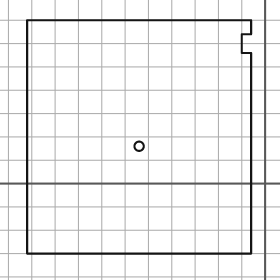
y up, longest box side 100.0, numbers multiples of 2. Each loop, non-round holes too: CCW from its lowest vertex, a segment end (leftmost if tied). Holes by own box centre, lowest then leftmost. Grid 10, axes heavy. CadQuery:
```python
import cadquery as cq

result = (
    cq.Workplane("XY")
    .moveTo(-102.0, -30.0)
    .lineTo(-6.0, -30.0)
    .lineTo(-6.0, 56.0)
    .lineTo(-10.0, 56.0)
    .lineTo(-10.0, 64.0)
    .lineTo(-6.0, 64.0)
    .lineTo(-6.0, 70.0)
    .lineTo(-102.0, 70.0)
    .close()
    .moveTo(-54.0, 16.0)
    .circle(2.0)
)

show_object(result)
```